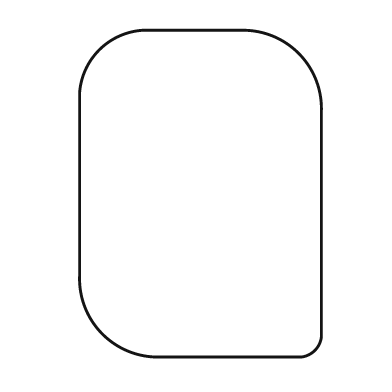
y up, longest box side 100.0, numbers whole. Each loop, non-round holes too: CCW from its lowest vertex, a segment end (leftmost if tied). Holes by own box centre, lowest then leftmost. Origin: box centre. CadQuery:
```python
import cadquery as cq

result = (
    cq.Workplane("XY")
    .moveTo(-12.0, -50.0)
    .lineTo(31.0, -50.0)
    .threePointArc((35.0, -48.0), (37.0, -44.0))
    .lineTo(37.0, 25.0)
    .threePointArc((30.0, 43.0), (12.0, 50.0))
    .lineTo(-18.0, 50.0)
    .threePointArc((-31.0, 44.0), (-37.0, 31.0))
    .lineTo(-37.0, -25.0)
    .threePointArc((-30.0, -43.0), (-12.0, -50.0))
    .close()
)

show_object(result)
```